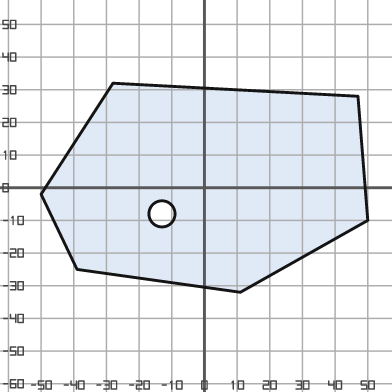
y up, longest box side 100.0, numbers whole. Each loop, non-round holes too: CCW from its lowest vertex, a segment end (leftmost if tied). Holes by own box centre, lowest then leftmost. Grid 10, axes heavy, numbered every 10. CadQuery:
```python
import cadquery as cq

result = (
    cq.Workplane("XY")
    .moveTo(11.0, -32.0)
    .lineTo(50.0, -10.0)
    .lineTo(47.0, 28.0)
    .lineTo(-28.0, 32.0)
    .lineTo(-50.0, -2.0)
    .lineTo(-39.0, -25.0)
    .close()
    .moveTo(-13.0, -8.0)
    .circle(4.0)
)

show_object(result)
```